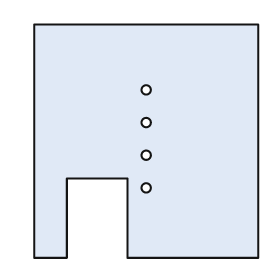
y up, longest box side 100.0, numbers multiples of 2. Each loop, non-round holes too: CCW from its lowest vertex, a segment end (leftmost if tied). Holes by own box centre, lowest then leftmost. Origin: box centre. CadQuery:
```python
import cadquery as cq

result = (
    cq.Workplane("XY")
    .moveTo(-48.0, -50.0)
    .lineTo(-34.0, -50.0)
    .lineTo(-34.0, -16.0)
    .lineTo(-8.0, -16.0)
    .lineTo(-8.0, -50.0)
    .lineTo(48.0, -50.0)
    .lineTo(48.0, 50.0)
    .lineTo(-48.0, 50.0)
    .close()
    .moveTo(0.0, -20.0)
    .circle(2.0)
    .moveTo(0.0, -6.0)
    .circle(2.0)
    .moveTo(0.0, 8.0)
    .circle(2.0)
    .moveTo(0.0, 22.0)
    .circle(2.0)
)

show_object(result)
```